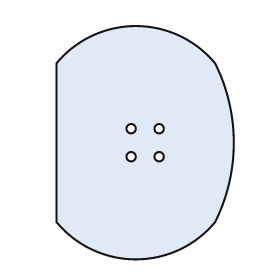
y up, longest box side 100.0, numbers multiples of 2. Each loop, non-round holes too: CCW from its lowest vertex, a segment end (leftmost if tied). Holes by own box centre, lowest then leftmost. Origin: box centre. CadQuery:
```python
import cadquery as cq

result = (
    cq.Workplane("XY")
    .moveTo(-38.0, -34.0)
    .threePointArc((-4.0, -50.0), (30.0, -34.0))
    .threePointArc((38.0, 0.0), (30.0, 34.0))
    .threePointArc((-4.0, 50.0), (-38.0, 34.0))
    .close()
    .moveTo(-6.0, -6.0)
    .circle(2.0)
    .moveTo(6.0, -6.0)
    .circle(2.0)
    .moveTo(-6.0, 6.0)
    .circle(2.0)
    .moveTo(6.0, 6.0)
    .circle(2.0)
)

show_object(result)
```